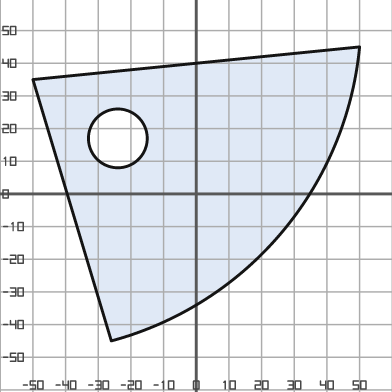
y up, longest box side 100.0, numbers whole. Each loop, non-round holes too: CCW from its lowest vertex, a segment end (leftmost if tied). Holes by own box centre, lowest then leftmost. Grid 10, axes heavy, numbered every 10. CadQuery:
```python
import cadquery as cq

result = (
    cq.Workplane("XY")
    .moveTo(-26.0, -45.0)
    .threePointArc((26.0, -12.0), (50.0, 45.0))
    .lineTo(-50.0, 35.0)
    .close()
    .moveTo(-24.0, 17.0)
    .circle(9.0)
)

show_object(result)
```